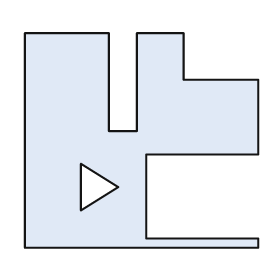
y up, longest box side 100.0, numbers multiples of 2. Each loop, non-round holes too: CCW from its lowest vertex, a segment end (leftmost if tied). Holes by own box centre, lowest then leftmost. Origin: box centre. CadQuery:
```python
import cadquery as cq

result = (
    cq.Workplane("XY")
    .moveTo(-50.0, -46.0)
    .lineTo(50.0, -46.0)
    .lineTo(50.0, -42.0)
    .lineTo(2.0, -42.0)
    .lineTo(2.0, -6.0)
    .lineTo(50.0, -6.0)
    .lineTo(50.0, 26.0)
    .lineTo(18.0, 26.0)
    .lineTo(18.0, 46.0)
    .lineTo(-2.0, 46.0)
    .lineTo(-2.0, 4.0)
    .lineTo(-14.0, 4.0)
    .lineTo(-14.0, 46.0)
    .lineTo(-50.0, 46.0)
    .close()
    .moveTo(-26.0, -30.0)
    .lineTo(-10.0, -20.0)
    .lineTo(-26.0, -10.0)
    .close()
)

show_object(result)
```